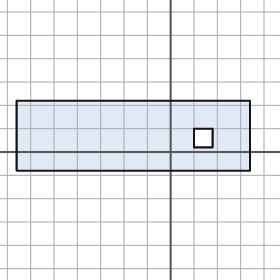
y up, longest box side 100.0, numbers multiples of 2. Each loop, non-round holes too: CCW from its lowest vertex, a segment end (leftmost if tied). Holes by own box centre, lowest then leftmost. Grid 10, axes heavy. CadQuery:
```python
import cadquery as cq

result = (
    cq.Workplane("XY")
    .moveTo(-66.0, -8.0)
    .lineTo(34.0, -8.0)
    .lineTo(34.0, 22.0)
    .lineTo(-66.0, 22.0)
    .close()
    .moveTo(10.0, 2.0)
    .lineTo(18.0, 2.0)
    .lineTo(18.0, 10.0)
    .lineTo(10.0, 10.0)
    .close()
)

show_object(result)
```